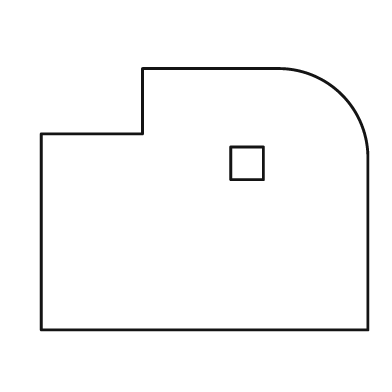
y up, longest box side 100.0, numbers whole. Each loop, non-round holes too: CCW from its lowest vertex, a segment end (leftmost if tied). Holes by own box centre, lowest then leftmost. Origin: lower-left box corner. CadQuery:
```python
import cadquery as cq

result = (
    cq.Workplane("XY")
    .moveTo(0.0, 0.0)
    .lineTo(100.0, 0.0)
    .lineTo(100.0, 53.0)
    .threePointArc((92.0, 72.0), (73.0, 80.0))
    .lineTo(31.0, 80.0)
    .lineTo(31.0, 60.0)
    .lineTo(0.0, 60.0)
    .close()
    .moveTo(58.0, 46.0)
    .lineTo(68.0, 46.0)
    .lineTo(68.0, 56.0)
    .lineTo(58.0, 56.0)
    .close()
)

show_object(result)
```